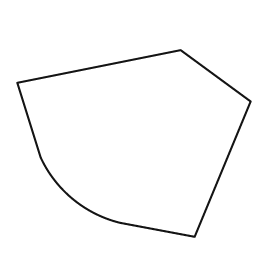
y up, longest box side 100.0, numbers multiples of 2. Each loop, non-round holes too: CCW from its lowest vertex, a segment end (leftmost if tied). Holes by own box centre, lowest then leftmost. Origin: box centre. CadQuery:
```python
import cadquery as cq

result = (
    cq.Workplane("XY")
    .moveTo(26.0, -40.0)
    .lineTo(50.0, 18.0)
    .lineTo(20.0, 40.0)
    .lineTo(-50.0, 26.0)
    .lineTo(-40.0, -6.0)
    .threePointArc((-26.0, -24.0), (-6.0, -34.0))
    .close()
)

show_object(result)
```